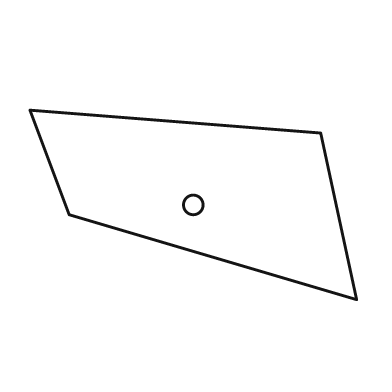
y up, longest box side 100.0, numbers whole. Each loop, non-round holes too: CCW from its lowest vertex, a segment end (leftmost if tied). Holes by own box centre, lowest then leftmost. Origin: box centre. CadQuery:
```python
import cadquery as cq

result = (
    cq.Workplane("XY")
    .moveTo(50.0, -29.0)
    .lineTo(39.0, 22.0)
    .lineTo(-50.0, 29.0)
    .lineTo(-38.0, -3.0)
    .close()
    .moveTo(0.0, 0.0)
    .circle(3.0)
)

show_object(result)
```